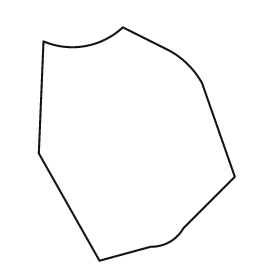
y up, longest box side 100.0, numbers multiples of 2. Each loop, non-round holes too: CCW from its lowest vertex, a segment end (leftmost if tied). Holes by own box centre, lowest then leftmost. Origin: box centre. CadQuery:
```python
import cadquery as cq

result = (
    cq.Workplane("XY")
    .moveTo(-16.0, -50.0)
    .lineTo(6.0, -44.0)
    .threePointArc((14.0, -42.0), (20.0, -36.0))
    .lineTo(42.0, -14.0)
    .lineTo(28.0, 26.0)
    .threePointArc((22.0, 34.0), (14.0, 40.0))
    .lineTo(-6.0, 50.0)
    .threePointArc((-22.0, 42.0), (-40.0, 44.0))
    .lineTo(-42.0, -4.0)
    .close()
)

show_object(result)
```